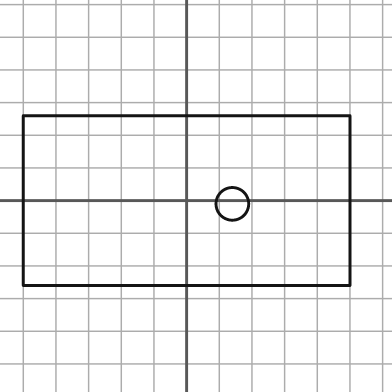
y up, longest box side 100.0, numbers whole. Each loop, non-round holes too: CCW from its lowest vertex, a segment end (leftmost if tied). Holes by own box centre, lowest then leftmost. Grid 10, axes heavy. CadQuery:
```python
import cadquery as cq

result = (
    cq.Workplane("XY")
    .moveTo(-50.0, -26.0)
    .lineTo(50.0, -26.0)
    .lineTo(50.0, 26.0)
    .lineTo(-50.0, 26.0)
    .close()
    .moveTo(14.0, -1.0)
    .circle(5.0)
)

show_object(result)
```